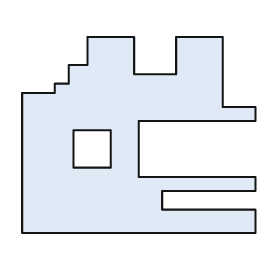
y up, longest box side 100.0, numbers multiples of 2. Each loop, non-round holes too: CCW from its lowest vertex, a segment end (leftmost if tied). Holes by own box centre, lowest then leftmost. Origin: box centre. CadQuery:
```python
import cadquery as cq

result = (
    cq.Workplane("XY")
    .moveTo(-50.0, -42.0)
    .lineTo(50.0, -42.0)
    .lineTo(50.0, -32.0)
    .lineTo(10.0, -32.0)
    .lineTo(10.0, -24.0)
    .lineTo(50.0, -24.0)
    .lineTo(50.0, -18.0)
    .lineTo(0.0, -18.0)
    .lineTo(0.0, 6.0)
    .lineTo(50.0, 6.0)
    .lineTo(50.0, 12.0)
    .lineTo(36.0, 12.0)
    .lineTo(36.0, 42.0)
    .lineTo(16.0, 42.0)
    .lineTo(16.0, 26.0)
    .lineTo(-2.0, 26.0)
    .lineTo(-2.0, 42.0)
    .lineTo(-22.0, 42.0)
    .lineTo(-22.0, 30.0)
    .lineTo(-30.0, 30.0)
    .lineTo(-30.0, 22.0)
    .lineTo(-36.0, 22.0)
    .lineTo(-36.0, 18.0)
    .lineTo(-50.0, 18.0)
    .close()
    .moveTo(-28.0, -14.0)
    .lineTo(-12.0, -14.0)
    .lineTo(-12.0, 2.0)
    .lineTo(-28.0, 2.0)
    .close()
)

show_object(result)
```